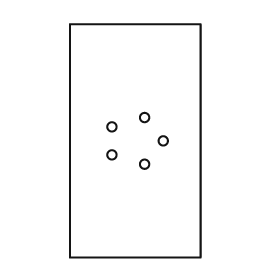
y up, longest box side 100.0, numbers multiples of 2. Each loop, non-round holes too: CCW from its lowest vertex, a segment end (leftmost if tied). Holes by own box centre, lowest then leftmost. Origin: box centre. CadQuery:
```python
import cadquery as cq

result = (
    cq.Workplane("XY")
    .moveTo(-28.0, -50.0)
    .lineTo(28.0, -50.0)
    .lineTo(28.0, 50.0)
    .lineTo(-28.0, 50.0)
    .close()
    .moveTo(4.0, -10.0)
    .circle(2.0)
    .moveTo(-10.0, -6.0)
    .circle(2.0)
    .moveTo(12.0, 0.0)
    .circle(2.0)
    .moveTo(-10.0, 6.0)
    .circle(2.0)
    .moveTo(4.0, 10.0)
    .circle(2.0)
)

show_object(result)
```